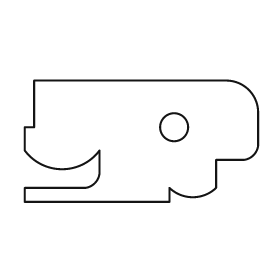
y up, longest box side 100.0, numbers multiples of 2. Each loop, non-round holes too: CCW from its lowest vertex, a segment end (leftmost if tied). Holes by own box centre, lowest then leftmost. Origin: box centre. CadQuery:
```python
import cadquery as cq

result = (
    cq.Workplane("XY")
    .moveTo(-50.0, -26.0)
    .lineTo(12.0, -26.0)
    .lineTo(12.0, -20.0)
    .threePointArc((22.0, -24.0), (32.0, -20.0))
    .lineTo(32.0, -8.0)
    .lineTo(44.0, -8.0)
    .threePointArc((48.0, -6.0), (50.0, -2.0))
    .lineTo(50.0, 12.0)
    .threePointArc((46.0, 22.0), (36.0, 26.0))
    .lineTo(-46.0, 26.0)
    .lineTo(-46.0, 6.0)
    .lineTo(-50.0, 6.0)
    .lineTo(-50.0, -4.0)
    .threePointArc((-34.0, -12.0), (-18.0, -4.0))
    .lineTo(-18.0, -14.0)
    .threePointArc((-20.0, -18.0), (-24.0, -20.0))
    .lineTo(-50.0, -20.0)
    .close()
    .moveTo(14.0, 6.0)
    .circle(6.0)
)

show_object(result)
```